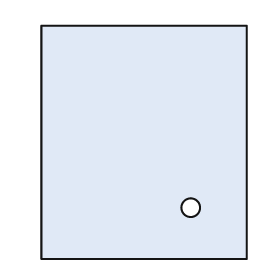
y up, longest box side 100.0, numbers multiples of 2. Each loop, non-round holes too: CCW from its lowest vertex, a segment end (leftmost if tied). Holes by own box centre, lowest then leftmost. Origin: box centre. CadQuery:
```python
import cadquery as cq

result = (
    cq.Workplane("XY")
    .moveTo(-44.0, -50.0)
    .lineTo(44.0, -50.0)
    .lineTo(44.0, 50.0)
    .lineTo(-44.0, 50.0)
    .close()
    .moveTo(20.0, -28.0)
    .circle(4.0)
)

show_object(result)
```